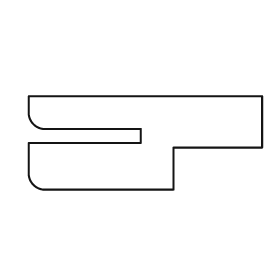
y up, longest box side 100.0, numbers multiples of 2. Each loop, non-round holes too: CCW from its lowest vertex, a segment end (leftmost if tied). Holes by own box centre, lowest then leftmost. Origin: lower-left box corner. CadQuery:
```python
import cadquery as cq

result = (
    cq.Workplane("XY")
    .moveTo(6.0, 0.0)
    .lineTo(62.0, 0.0)
    .lineTo(62.0, 18.0)
    .lineTo(100.0, 18.0)
    .lineTo(100.0, 40.0)
    .lineTo(0.0, 40.0)
    .lineTo(0.0, 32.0)
    .threePointArc((2.0, 28.0), (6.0, 26.0))
    .lineTo(48.0, 26.0)
    .lineTo(48.0, 20.0)
    .lineTo(0.0, 20.0)
    .lineTo(0.0, 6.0)
    .threePointArc((2.0, 2.0), (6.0, 0.0))
    .close()
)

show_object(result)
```